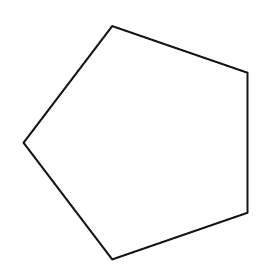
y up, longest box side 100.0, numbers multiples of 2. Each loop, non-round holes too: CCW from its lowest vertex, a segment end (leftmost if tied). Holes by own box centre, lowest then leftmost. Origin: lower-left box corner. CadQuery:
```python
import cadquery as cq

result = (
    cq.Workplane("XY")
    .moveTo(38.0, 0.0)
    .lineTo(96.0, 20.0)
    .lineTo(96.0, 80.0)
    .lineTo(38.0, 100.0)
    .lineTo(0.0, 50.0)
    .close()
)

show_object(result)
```